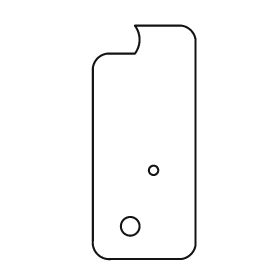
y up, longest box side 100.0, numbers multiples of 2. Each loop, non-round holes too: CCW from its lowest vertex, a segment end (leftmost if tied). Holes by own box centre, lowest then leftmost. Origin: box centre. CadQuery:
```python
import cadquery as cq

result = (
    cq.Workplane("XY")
    .moveTo(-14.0, -50.0)
    .lineTo(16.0, -50.0)
    .threePointArc((20.0, -48.0), (22.0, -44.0))
    .lineTo(22.0, 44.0)
    .threePointArc((20.0, 48.0), (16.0, 50.0))
    .lineTo(-4.0, 50.0)
    .threePointArc((-2.0, 44.0), (-4.0, 38.0))
    .lineTo(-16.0, 38.0)
    .threePointArc((-20.0, 36.0), (-22.0, 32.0))
    .lineTo(-22.0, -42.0)
    .threePointArc((-20.0, -48.0), (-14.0, -50.0))
    .close()
    .moveTo(-6.0, -36.0)
    .circle(4.0)
    .moveTo(4.0, -12.0)
    .circle(2.0)
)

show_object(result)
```